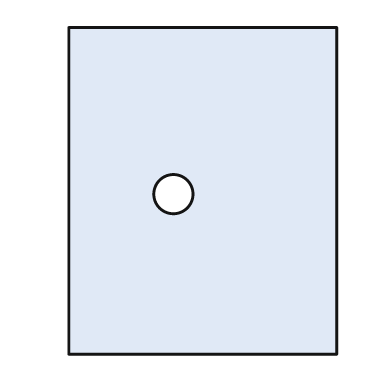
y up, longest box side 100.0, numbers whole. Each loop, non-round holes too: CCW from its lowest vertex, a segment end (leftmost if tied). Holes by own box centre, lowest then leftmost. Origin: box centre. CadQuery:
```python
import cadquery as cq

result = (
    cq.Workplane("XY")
    .moveTo(-41.0, -50.0)
    .lineTo(41.0, -50.0)
    .lineTo(41.0, 50.0)
    .lineTo(-41.0, 50.0)
    .close()
    .moveTo(-9.0, -1.0)
    .circle(6.0)
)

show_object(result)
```